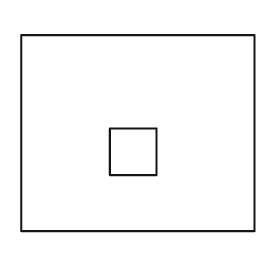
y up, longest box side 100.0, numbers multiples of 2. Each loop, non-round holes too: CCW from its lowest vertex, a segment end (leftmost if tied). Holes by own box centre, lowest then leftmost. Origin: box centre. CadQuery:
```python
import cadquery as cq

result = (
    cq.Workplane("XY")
    .moveTo(-50.0, -42.0)
    .lineTo(50.0, -42.0)
    .lineTo(50.0, 42.0)
    .lineTo(-50.0, 42.0)
    .close()
    .moveTo(-12.0, -18.0)
    .lineTo(8.0, -18.0)
    .lineTo(8.0, 2.0)
    .lineTo(-12.0, 2.0)
    .close()
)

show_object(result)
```